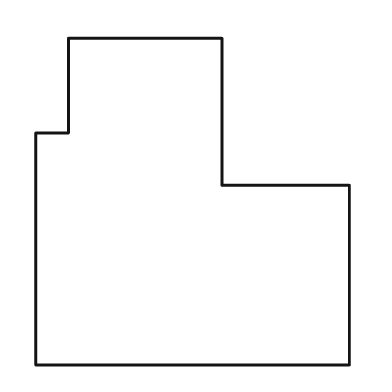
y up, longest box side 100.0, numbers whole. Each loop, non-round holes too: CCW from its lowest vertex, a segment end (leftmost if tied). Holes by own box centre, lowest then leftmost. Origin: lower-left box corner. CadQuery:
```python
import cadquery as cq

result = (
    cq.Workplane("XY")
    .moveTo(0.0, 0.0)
    .lineTo(96.0, 0.0)
    .lineTo(96.0, 55.0)
    .lineTo(57.0, 55.0)
    .lineTo(57.0, 100.0)
    .lineTo(10.0, 100.0)
    .lineTo(10.0, 71.0)
    .lineTo(0.0, 71.0)
    .close()
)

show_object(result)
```